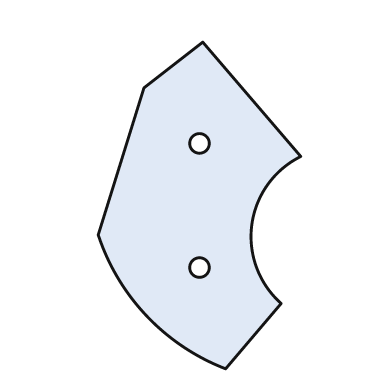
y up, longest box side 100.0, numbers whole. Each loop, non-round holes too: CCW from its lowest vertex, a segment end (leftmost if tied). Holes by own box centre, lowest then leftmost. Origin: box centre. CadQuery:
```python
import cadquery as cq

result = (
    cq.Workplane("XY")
    .moveTo(8.0, -50.0)
    .lineTo(25.0, -30.0)
    .threePointArc((16.0, -6.0), (31.0, 15.0))
    .lineTo(1.0, 50.0)
    .lineTo(-17.0, 36.0)
    .lineTo(-31.0, -9.0)
    .threePointArc((-16.0, -34.0), (8.0, -50.0))
    .close()
    .moveTo(0.0, -19.0)
    .circle(3.0)
    .moveTo(0.0, 19.0)
    .circle(3.0)
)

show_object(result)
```